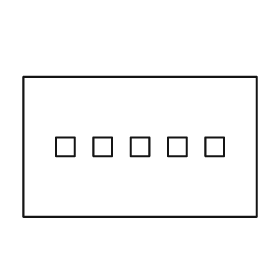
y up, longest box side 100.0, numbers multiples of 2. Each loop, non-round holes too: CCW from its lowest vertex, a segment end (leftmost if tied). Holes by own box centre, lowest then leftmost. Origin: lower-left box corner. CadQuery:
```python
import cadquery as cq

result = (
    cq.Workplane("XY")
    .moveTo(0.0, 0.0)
    .lineTo(100.0, 0.0)
    .lineTo(100.0, 60.0)
    .lineTo(0.0, 60.0)
    .close()
    .moveTo(14.0, 26.0)
    .lineTo(22.0, 26.0)
    .lineTo(22.0, 34.0)
    .lineTo(14.0, 34.0)
    .close()
    .moveTo(30.0, 26.0)
    .lineTo(38.0, 26.0)
    .lineTo(38.0, 34.0)
    .lineTo(30.0, 34.0)
    .close()
    .moveTo(46.0, 26.0)
    .lineTo(54.0, 26.0)
    .lineTo(54.0, 34.0)
    .lineTo(46.0, 34.0)
    .close()
    .moveTo(62.0, 26.0)
    .lineTo(70.0, 26.0)
    .lineTo(70.0, 34.0)
    .lineTo(62.0, 34.0)
    .close()
    .moveTo(78.0, 26.0)
    .lineTo(86.0, 26.0)
    .lineTo(86.0, 34.0)
    .lineTo(78.0, 34.0)
    .close()
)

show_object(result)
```